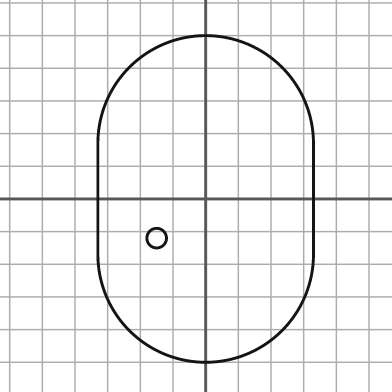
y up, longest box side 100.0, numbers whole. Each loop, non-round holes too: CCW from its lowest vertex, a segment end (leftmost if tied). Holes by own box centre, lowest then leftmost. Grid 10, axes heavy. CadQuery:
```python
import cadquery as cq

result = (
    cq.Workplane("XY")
    .moveTo(-33.0, -17.0)
    .threePointArc((0.0, -50.0), (33.0, -17.0))
    .lineTo(33.0, 17.0)
    .threePointArc((0.0, 50.0), (-33.0, 17.0))
    .close()
    .moveTo(-15.0, -12.0)
    .circle(3.0)
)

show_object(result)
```